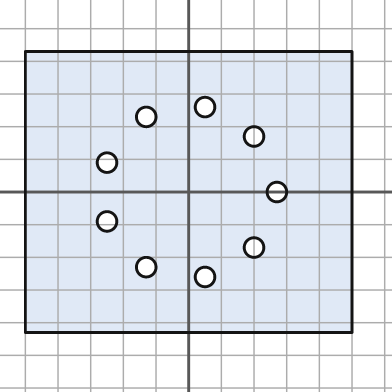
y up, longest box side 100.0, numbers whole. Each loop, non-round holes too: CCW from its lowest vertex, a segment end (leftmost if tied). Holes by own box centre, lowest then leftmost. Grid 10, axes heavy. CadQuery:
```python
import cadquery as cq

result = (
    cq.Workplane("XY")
    .moveTo(-50.0, -43.0)
    .lineTo(50.0, -43.0)
    .lineTo(50.0, 43.0)
    .lineTo(-50.0, 43.0)
    .close()
    .moveTo(5.0, -26.0)
    .circle(3.0)
    .moveTo(-13.0, -23.0)
    .circle(3.0)
    .moveTo(20.0, -17.0)
    .circle(3.0)
    .moveTo(-25.0, -9.0)
    .circle(3.0)
    .moveTo(27.0, 0.0)
    .circle(3.0)
    .moveTo(-25.0, 9.0)
    .circle(3.0)
    .moveTo(20.0, 17.0)
    .circle(3.0)
    .moveTo(-13.0, 23.0)
    .circle(3.0)
    .moveTo(5.0, 26.0)
    .circle(3.0)
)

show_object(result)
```